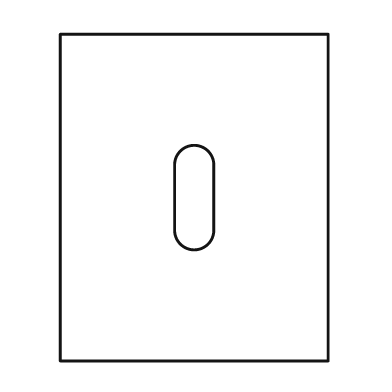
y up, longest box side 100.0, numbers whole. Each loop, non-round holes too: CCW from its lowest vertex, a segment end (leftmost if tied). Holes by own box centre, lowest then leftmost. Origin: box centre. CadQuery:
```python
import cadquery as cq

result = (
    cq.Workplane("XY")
    .moveTo(-41.0, -50.0)
    .lineTo(41.0, -50.0)
    .lineTo(41.0, 50.0)
    .lineTo(-41.0, 50.0)
    .close()
    .moveTo(-6.0, -10.0)
    .threePointArc((0.0, -16.0), (6.0, -10.0))
    .lineTo(6.0, 10.0)
    .threePointArc((0.0, 16.0), (-6.0, 10.0))
    .close()
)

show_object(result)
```